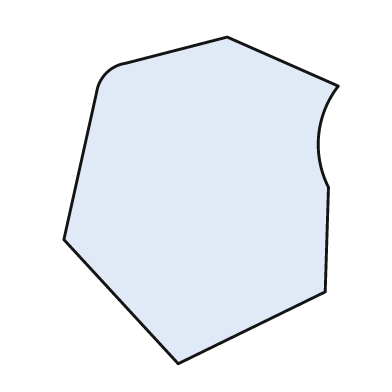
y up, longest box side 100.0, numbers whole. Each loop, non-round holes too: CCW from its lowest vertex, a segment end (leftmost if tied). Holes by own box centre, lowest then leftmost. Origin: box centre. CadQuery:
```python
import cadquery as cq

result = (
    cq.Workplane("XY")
    .moveTo(-7.0, -50.0)
    .lineTo(38.0, -28.0)
    .lineTo(39.0, 4.0)
    .threePointArc((36.0, 20.0), (42.0, 35.0))
    .lineTo(8.0, 50.0)
    .lineTo(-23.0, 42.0)
    .threePointArc((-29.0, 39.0), (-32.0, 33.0))
    .lineTo(-42.0, -12.0)
    .close()
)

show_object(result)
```